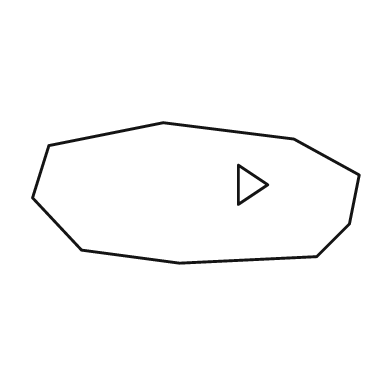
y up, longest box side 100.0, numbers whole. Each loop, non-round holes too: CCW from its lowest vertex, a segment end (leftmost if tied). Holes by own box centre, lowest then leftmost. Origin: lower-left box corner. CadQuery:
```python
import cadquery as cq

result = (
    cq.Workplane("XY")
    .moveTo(45.0, 0.0)
    .lineTo(87.0, 2.0)
    .lineTo(97.0, 12.0)
    .lineTo(100.0, 27.0)
    .lineTo(80.0, 38.0)
    .lineTo(40.0, 43.0)
    .lineTo(5.0, 36.0)
    .lineTo(0.0, 20.0)
    .lineTo(15.0, 4.0)
    .close()
    .moveTo(63.0, 18.0)
    .lineTo(72.0, 24.0)
    .lineTo(63.0, 30.0)
    .close()
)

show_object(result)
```